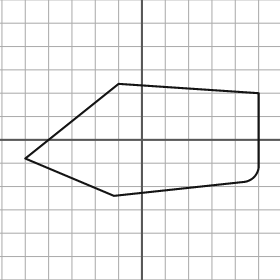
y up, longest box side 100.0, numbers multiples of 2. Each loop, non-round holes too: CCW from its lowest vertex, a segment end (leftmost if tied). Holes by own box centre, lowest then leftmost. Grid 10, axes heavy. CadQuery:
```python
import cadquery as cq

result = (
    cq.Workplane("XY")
    .moveTo(-12.0, -24.0)
    .lineTo(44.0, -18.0)
    .threePointArc((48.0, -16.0), (50.0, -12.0))
    .lineTo(50.0, 20.0)
    .lineTo(-10.0, 24.0)
    .lineTo(-50.0, -8.0)
    .close()
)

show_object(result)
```